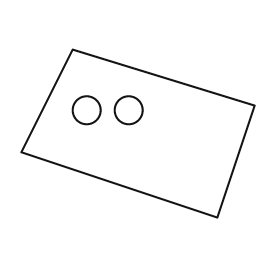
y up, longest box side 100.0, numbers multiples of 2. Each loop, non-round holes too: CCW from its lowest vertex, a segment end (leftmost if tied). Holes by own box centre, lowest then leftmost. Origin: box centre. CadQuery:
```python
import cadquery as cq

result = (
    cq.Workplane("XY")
    .moveTo(34.0, -36.0)
    .lineTo(50.0, 12.0)
    .lineTo(-28.0, 36.0)
    .lineTo(-50.0, -8.0)
    .close()
    .moveTo(-22.0, 10.0)
    .circle(6.0)
    .moveTo(-4.0, 10.0)
    .circle(6.0)
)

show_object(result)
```